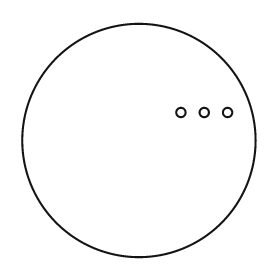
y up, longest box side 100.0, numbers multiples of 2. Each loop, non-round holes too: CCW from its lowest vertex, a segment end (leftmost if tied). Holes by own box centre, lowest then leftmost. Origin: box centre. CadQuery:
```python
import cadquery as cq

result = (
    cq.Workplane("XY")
    .moveTo(0.0, 0.0)
    .circle(50.0)
    .moveTo(18.0, 12.0)
    .circle(2.0)
    .moveTo(28.0, 12.0)
    .circle(2.0)
    .moveTo(38.0, 12.0)
    .circle(2.0)
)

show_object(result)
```